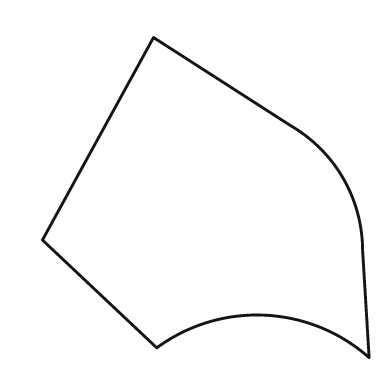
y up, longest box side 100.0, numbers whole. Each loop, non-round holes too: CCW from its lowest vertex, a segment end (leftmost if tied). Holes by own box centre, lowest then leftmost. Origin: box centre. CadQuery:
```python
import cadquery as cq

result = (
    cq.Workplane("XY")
    .moveTo(50.0, -49.0)
    .lineTo(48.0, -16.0)
    .threePointArc((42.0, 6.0), (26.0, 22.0))
    .lineTo(-16.0, 49.0)
    .lineTo(-50.0, -13.0)
    .lineTo(-15.0, -46.0)
    .threePointArc((18.0, -36.0), (50.0, -49.0))
    .close()
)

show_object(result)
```